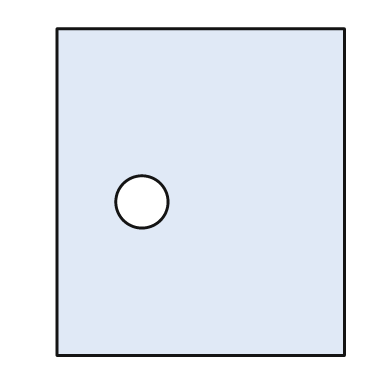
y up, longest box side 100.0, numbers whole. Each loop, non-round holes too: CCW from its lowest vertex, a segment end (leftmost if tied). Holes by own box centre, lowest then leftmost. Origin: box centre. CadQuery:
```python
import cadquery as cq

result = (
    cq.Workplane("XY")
    .moveTo(-44.0, -50.0)
    .lineTo(44.0, -50.0)
    .lineTo(44.0, 50.0)
    .lineTo(-44.0, 50.0)
    .close()
    .moveTo(-18.0, -3.0)
    .circle(8.0)
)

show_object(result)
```